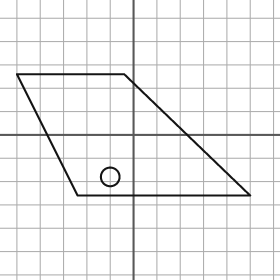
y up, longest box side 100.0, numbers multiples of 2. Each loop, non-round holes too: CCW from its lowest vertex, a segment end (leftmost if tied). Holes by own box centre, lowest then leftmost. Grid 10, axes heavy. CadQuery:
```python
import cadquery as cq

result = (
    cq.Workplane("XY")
    .moveTo(-24.0, -26.0)
    .lineTo(50.0, -26.0)
    .lineTo(-4.0, 26.0)
    .lineTo(-50.0, 26.0)
    .close()
    .moveTo(-10.0, -18.0)
    .circle(4.0)
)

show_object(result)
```